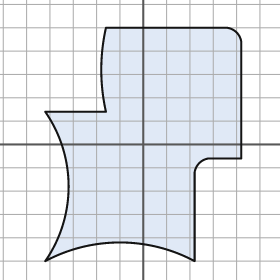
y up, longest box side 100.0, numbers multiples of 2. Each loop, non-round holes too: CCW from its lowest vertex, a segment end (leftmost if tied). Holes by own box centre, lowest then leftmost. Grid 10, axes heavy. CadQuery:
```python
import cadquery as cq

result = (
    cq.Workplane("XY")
    .moveTo(-42.0, -50.0)
    .threePointArc((-10.0, -42.0), (22.0, -50.0))
    .lineTo(22.0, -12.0)
    .threePointArc((24.0, -8.0), (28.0, -6.0))
    .lineTo(42.0, -6.0)
    .lineTo(42.0, 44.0)
    .threePointArc((40.0, 48.0), (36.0, 50.0))
    .lineTo(-16.0, 50.0)
    .threePointArc((-18.0, 32.0), (-16.0, 14.0))
    .lineTo(-42.0, 14.0)
    .threePointArc((-32.0, -18.0), (-42.0, -50.0))
    .close()
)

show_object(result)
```